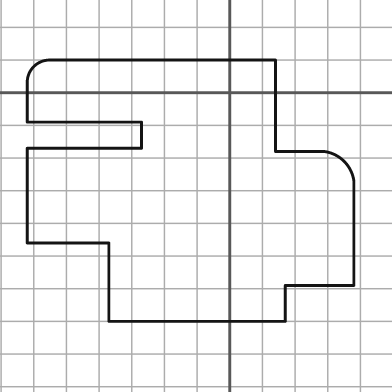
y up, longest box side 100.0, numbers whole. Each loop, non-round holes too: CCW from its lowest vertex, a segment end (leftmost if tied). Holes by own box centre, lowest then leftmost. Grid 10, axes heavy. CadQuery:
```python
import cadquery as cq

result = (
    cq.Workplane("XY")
    .moveTo(-37.0, -70.0)
    .lineTo(17.0, -70.0)
    .lineTo(17.0, -59.0)
    .lineTo(38.0, -59.0)
    .lineTo(38.0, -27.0)
    .threePointArc((35.0, -21.0), (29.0, -18.0))
    .lineTo(14.0, -18.0)
    .lineTo(14.0, 10.0)
    .lineTo(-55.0, 10.0)
    .threePointArc((-60.0, 8.0), (-62.0, 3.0))
    .lineTo(-62.0, -9.0)
    .lineTo(-27.0, -9.0)
    .lineTo(-27.0, -17.0)
    .lineTo(-62.0, -17.0)
    .lineTo(-62.0, -46.0)
    .lineTo(-37.0, -46.0)
    .close()
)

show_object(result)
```